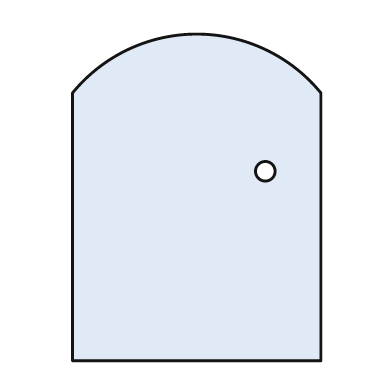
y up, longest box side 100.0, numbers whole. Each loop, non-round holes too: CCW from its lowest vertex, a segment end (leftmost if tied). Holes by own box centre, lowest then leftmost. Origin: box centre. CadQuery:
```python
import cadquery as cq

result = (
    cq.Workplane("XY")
    .moveTo(-38.0, -50.0)
    .lineTo(38.0, -50.0)
    .lineTo(38.0, 32.0)
    .threePointArc((0.0, 50.0), (-38.0, 32.0))
    .close()
    .moveTo(21.0, 8.0)
    .circle(3.0)
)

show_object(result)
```